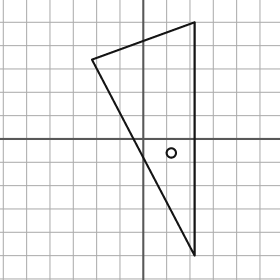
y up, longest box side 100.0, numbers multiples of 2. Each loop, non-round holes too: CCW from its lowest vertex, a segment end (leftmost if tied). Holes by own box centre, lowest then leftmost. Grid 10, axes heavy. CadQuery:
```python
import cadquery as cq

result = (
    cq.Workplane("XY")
    .moveTo(22.0, -50.0)
    .lineTo(22.0, 50.0)
    .lineTo(-22.0, 34.0)
    .close()
    .moveTo(12.0, -6.0)
    .circle(2.0)
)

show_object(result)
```